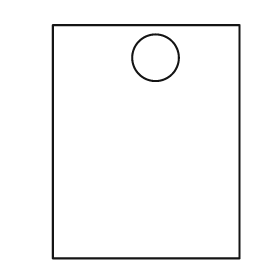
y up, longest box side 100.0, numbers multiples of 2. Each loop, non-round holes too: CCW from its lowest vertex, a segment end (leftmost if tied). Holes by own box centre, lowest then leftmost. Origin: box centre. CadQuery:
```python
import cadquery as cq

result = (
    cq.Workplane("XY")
    .moveTo(-40.0, -50.0)
    .lineTo(40.0, -50.0)
    .lineTo(40.0, 50.0)
    .lineTo(-40.0, 50.0)
    .close()
    .moveTo(4.0, 36.0)
    .circle(10.0)
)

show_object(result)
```